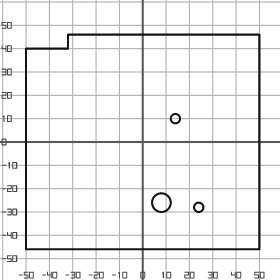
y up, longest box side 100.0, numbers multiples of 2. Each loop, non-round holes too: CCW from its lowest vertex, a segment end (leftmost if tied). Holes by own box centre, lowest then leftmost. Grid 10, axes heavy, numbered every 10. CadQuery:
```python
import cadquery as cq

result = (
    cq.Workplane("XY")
    .moveTo(-50.0, -46.0)
    .lineTo(50.0, -46.0)
    .lineTo(50.0, 46.0)
    .lineTo(-32.0, 46.0)
    .lineTo(-32.0, 40.0)
    .lineTo(-50.0, 40.0)
    .close()
    .moveTo(24.0, -28.0)
    .circle(2.0)
    .moveTo(8.0, -26.0)
    .circle(4.0)
    .moveTo(14.0, 10.0)
    .circle(2.0)
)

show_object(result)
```